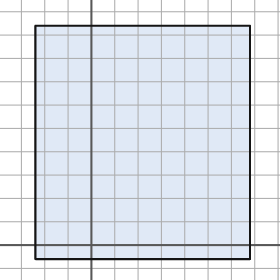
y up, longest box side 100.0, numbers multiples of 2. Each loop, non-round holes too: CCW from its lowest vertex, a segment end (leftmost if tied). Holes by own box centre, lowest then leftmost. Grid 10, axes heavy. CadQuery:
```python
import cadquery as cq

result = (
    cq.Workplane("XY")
    .moveTo(-24.0, -6.0)
    .lineTo(68.0, -6.0)
    .lineTo(68.0, 94.0)
    .lineTo(-24.0, 94.0)
    .close()
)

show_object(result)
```